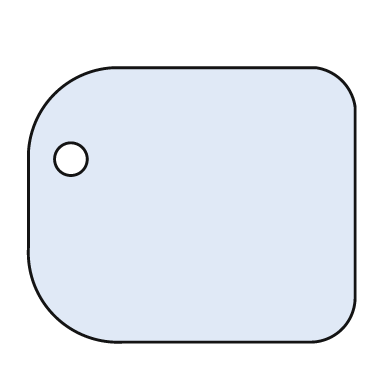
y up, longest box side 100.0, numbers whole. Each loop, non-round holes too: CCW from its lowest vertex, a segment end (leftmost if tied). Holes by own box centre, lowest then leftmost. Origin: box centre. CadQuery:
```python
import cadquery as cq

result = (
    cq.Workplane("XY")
    .moveTo(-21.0, -42.0)
    .lineTo(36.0, -42.0)
    .threePointArc((46.0, -38.0), (50.0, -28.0))
    .lineTo(50.0, 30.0)
    .threePointArc((46.0, 38.0), (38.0, 42.0))
    .lineTo(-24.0, 42.0)
    .threePointArc((-42.0, 34.0), (-50.0, 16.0))
    .lineTo(-50.0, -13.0)
    .threePointArc((-42.0, -34.0), (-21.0, -42.0))
    .close()
    .moveTo(-37.0, 14.0)
    .circle(5.0)
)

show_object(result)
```